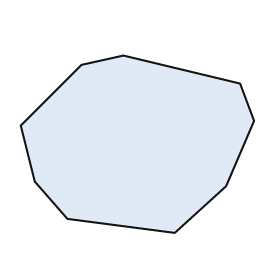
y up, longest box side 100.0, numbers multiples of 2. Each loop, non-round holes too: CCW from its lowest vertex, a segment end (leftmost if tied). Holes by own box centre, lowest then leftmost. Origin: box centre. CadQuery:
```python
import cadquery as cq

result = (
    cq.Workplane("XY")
    .moveTo(16.0, -38.0)
    .lineTo(38.0, -18.0)
    .lineTo(50.0, 10.0)
    .lineTo(44.0, 26.0)
    .lineTo(-6.0, 38.0)
    .lineTo(-24.0, 34.0)
    .lineTo(-50.0, 8.0)
    .lineTo(-44.0, -16.0)
    .lineTo(-30.0, -32.0)
    .close()
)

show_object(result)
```